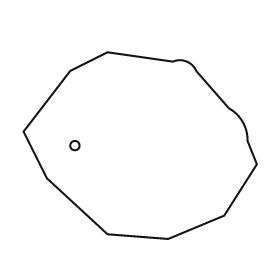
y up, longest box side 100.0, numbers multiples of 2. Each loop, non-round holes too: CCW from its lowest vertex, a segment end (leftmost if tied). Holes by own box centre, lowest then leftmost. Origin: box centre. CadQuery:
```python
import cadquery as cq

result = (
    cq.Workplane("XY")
    .moveTo(12.0, -40.0)
    .lineTo(36.0, -30.0)
    .lineTo(50.0, -8.0)
    .lineTo(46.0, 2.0)
    .threePointArc((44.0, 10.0), (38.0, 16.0))
    .lineTo(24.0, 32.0)
    .threePointArc((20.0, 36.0), (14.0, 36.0))
    .lineTo(-14.0, 40.0)
    .lineTo(-30.0, 32.0)
    .lineTo(-50.0, 6.0)
    .lineTo(-40.0, -14.0)
    .lineTo(-14.0, -38.0)
    .close()
    .moveTo(-28.0, 0.0)
    .circle(2.0)
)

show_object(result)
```